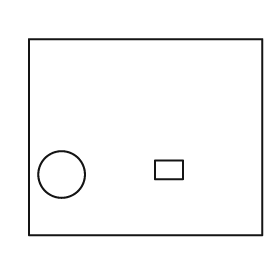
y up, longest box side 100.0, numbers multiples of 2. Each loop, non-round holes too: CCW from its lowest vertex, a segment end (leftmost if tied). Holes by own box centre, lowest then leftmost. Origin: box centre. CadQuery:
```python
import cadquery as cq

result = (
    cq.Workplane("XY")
    .moveTo(-50.0, -42.0)
    .lineTo(50.0, -42.0)
    .lineTo(50.0, 42.0)
    .lineTo(-50.0, 42.0)
    .close()
    .moveTo(-36.0, -16.0)
    .circle(10.0)
    .moveTo(4.0, -18.0)
    .lineTo(16.0, -18.0)
    .lineTo(16.0, -10.0)
    .lineTo(4.0, -10.0)
    .close()
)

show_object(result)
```